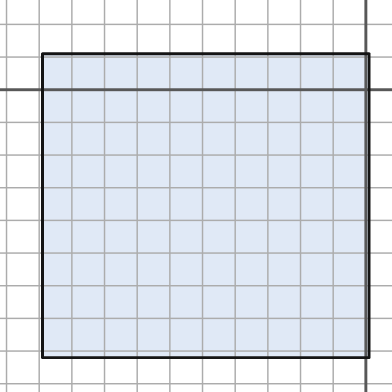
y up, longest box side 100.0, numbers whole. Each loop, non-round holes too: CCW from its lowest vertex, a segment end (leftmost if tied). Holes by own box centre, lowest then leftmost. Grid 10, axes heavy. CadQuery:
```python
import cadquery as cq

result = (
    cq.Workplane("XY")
    .moveTo(-99.0, -82.0)
    .lineTo(1.0, -82.0)
    .lineTo(1.0, 11.0)
    .lineTo(-99.0, 11.0)
    .close()
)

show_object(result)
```